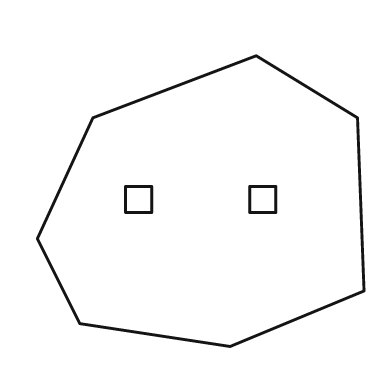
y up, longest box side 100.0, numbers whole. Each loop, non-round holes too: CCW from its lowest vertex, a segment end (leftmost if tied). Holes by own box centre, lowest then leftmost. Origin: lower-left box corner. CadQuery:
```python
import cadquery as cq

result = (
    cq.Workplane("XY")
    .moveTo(59.0, 0.0)
    .lineTo(100.0, 17.0)
    .lineTo(98.0, 70.0)
    .lineTo(67.0, 89.0)
    .lineTo(17.0, 70.0)
    .lineTo(0.0, 33.0)
    .lineTo(13.0, 7.0)
    .close()
    .moveTo(27.0, 41.0)
    .lineTo(35.0, 41.0)
    .lineTo(35.0, 49.0)
    .lineTo(27.0, 49.0)
    .close()
    .moveTo(65.0, 41.0)
    .lineTo(73.0, 41.0)
    .lineTo(73.0, 49.0)
    .lineTo(65.0, 49.0)
    .close()
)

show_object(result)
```